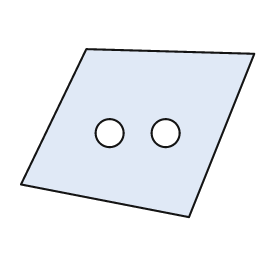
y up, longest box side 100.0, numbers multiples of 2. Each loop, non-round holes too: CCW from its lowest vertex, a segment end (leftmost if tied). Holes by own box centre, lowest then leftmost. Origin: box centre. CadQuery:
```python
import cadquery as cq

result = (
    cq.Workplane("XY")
    .moveTo(22.0, -36.0)
    .lineTo(50.0, 34.0)
    .lineTo(-22.0, 36.0)
    .lineTo(-50.0, -22.0)
    .close()
    .moveTo(-12.0, 0.0)
    .circle(6.0)
    .moveTo(12.0, 0.0)
    .circle(6.0)
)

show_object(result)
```